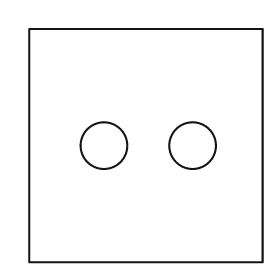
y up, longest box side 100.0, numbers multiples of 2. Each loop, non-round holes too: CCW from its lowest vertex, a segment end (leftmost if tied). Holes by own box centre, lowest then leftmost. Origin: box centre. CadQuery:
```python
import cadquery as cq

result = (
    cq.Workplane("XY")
    .moveTo(-50.0, -50.0)
    .lineTo(50.0, -50.0)
    .lineTo(50.0, 50.0)
    .lineTo(-50.0, 50.0)
    .close()
    .moveTo(-18.0, 0.0)
    .circle(10.0)
    .moveTo(20.0, 0.0)
    .circle(10.0)
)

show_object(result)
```